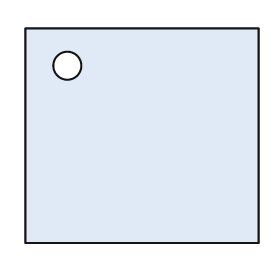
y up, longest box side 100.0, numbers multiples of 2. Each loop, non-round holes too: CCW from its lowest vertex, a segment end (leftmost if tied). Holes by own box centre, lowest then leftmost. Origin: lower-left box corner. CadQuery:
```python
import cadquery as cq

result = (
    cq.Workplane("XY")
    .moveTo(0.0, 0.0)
    .lineTo(100.0, 0.0)
    .lineTo(100.0, 92.0)
    .lineTo(0.0, 92.0)
    .close()
    .moveTo(18.0, 76.0)
    .circle(6.0)
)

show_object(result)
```